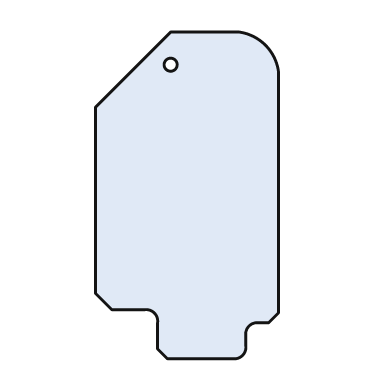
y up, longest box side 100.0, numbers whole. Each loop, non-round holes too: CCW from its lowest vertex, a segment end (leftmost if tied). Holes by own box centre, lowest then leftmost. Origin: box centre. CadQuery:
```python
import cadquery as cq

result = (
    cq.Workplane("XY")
    .moveTo(-6.0, -50.0)
    .lineTo(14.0, -50.0)
    .threePointArc((17.0, -49.0), (18.0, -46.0))
    .lineTo(18.0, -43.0)
    .threePointArc((19.0, -40.0), (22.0, -39.0))
    .lineTo(25.0, -39.0)
    .lineTo(28.0, -36.0)
    .lineTo(28.0, 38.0)
    .threePointArc((24.0, 46.0), (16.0, 50.0))
    .lineTo(-5.0, 50.0)
    .lineTo(-28.0, 27.0)
    .lineTo(-28.0, -30.0)
    .lineTo(-23.0, -35.0)
    .lineTo(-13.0, -35.0)
    .threePointArc((-10.0, -36.0), (-9.0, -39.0))
    .lineTo(-9.0, -47.0)
    .close()
    .moveTo(-5.0, 40.0)
    .circle(2.0)
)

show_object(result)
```